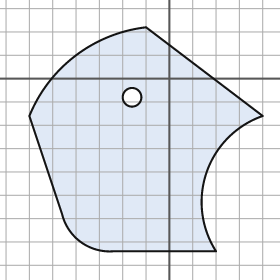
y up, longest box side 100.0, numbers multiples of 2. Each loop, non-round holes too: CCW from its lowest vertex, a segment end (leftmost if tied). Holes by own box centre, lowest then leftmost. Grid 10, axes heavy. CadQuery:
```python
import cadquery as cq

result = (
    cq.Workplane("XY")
    .moveTo(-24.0, -74.0)
    .lineTo(20.0, -74.0)
    .threePointArc((16.0, -40.0), (40.0, -16.0))
    .lineTo(-10.0, 22.0)
    .threePointArc((-40.0, 10.0), (-60.0, -16.0))
    .lineTo(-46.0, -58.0)
    .threePointArc((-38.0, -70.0), (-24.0, -74.0))
    .close()
    .moveTo(-16.0, -8.0)
    .circle(4.0)
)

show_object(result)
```